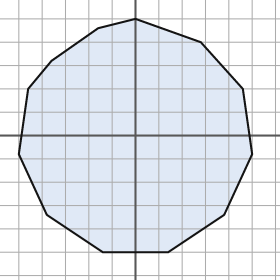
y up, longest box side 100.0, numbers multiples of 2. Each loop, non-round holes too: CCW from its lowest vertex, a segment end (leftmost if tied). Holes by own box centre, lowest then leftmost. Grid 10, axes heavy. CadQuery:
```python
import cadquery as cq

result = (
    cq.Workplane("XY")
    .moveTo(-14.0, -50.0)
    .lineTo(14.0, -50.0)
    .lineTo(38.0, -34.0)
    .lineTo(50.0, -8.0)
    .lineTo(46.0, 20.0)
    .lineTo(28.0, 40.0)
    .lineTo(0.0, 50.0)
    .lineTo(-16.0, 46.0)
    .lineTo(-36.0, 32.0)
    .lineTo(-46.0, 20.0)
    .lineTo(-50.0, -8.0)
    .lineTo(-38.0, -34.0)
    .close()
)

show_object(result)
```